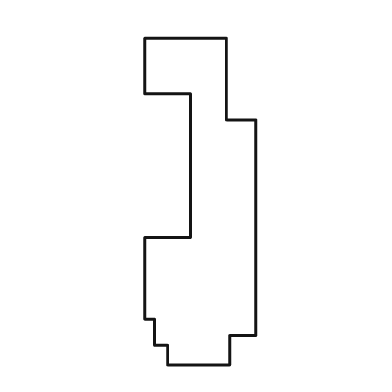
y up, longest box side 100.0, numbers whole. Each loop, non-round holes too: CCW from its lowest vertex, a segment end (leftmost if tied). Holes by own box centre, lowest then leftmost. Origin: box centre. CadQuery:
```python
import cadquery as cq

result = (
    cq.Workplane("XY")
    .moveTo(-10.0, -50.0)
    .lineTo(9.0, -50.0)
    .lineTo(9.0, -41.0)
    .lineTo(17.0, -41.0)
    .lineTo(17.0, 25.0)
    .lineTo(8.0, 25.0)
    .lineTo(8.0, 50.0)
    .lineTo(-17.0, 50.0)
    .lineTo(-17.0, 33.0)
    .lineTo(-3.0, 33.0)
    .lineTo(-3.0, -11.0)
    .lineTo(-17.0, -11.0)
    .lineTo(-17.0, -36.0)
    .lineTo(-14.0, -36.0)
    .lineTo(-14.0, -44.0)
    .lineTo(-10.0, -44.0)
    .close()
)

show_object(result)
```